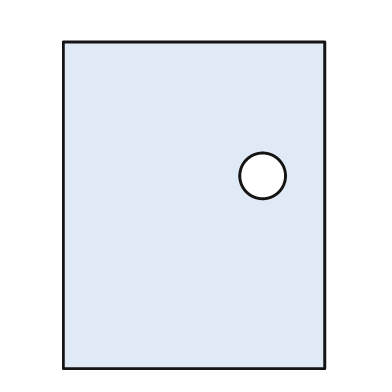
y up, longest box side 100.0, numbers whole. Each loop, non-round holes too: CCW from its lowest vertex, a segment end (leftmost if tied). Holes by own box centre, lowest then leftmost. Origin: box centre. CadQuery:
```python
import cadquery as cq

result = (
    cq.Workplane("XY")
    .moveTo(-40.0, -50.0)
    .lineTo(40.0, -50.0)
    .lineTo(40.0, 50.0)
    .lineTo(-40.0, 50.0)
    .close()
    .moveTo(21.0, 9.0)
    .circle(7.0)
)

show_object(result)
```